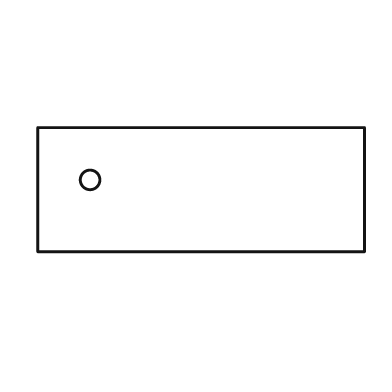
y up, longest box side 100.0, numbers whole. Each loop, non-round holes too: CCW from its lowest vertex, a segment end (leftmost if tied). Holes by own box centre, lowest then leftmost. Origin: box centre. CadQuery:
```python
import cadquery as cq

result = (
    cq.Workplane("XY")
    .moveTo(-50.0, -19.0)
    .lineTo(50.0, -19.0)
    .lineTo(50.0, 19.0)
    .lineTo(-50.0, 19.0)
    .close()
    .moveTo(-34.0, 3.0)
    .circle(3.0)
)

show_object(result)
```